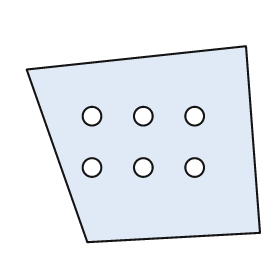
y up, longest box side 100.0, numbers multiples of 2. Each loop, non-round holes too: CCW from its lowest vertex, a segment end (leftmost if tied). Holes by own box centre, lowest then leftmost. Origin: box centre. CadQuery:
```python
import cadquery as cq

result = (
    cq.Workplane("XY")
    .moveTo(-24.0, -42.0)
    .lineTo(50.0, -38.0)
    .lineTo(44.0, 42.0)
    .lineTo(-50.0, 32.0)
    .close()
    .moveTo(-22.0, -10.0)
    .circle(4.0)
    .moveTo(0.0, -10.0)
    .circle(4.0)
    .moveTo(22.0, -10.0)
    .circle(4.0)
    .moveTo(-22.0, 12.0)
    .circle(4.0)
    .moveTo(0.0, 12.0)
    .circle(4.0)
    .moveTo(22.0, 12.0)
    .circle(4.0)
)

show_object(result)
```